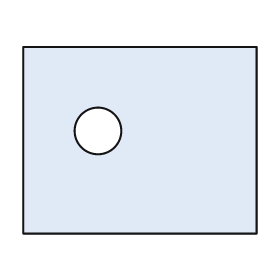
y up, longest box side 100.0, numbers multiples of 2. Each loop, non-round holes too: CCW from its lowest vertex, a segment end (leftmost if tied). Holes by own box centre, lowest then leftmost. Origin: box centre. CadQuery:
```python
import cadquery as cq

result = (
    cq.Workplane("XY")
    .moveTo(-50.0, -40.0)
    .lineTo(50.0, -40.0)
    .lineTo(50.0, 40.0)
    .lineTo(-50.0, 40.0)
    .close()
    .moveTo(-18.0, 4.0)
    .circle(10.0)
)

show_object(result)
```